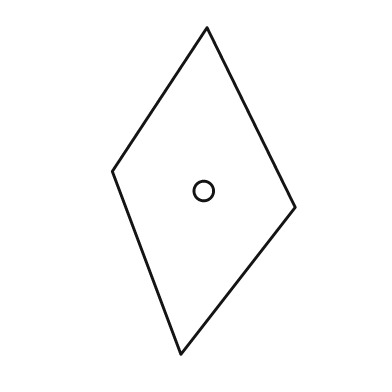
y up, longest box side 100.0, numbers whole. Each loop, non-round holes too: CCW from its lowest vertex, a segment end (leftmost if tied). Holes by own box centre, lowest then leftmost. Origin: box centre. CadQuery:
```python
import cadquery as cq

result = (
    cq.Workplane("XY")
    .moveTo(-7.0, -50.0)
    .lineTo(28.0, -5.0)
    .lineTo(1.0, 50.0)
    .lineTo(-28.0, 6.0)
    .close()
    .moveTo(0.0, 0.0)
    .circle(3.0)
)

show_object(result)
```